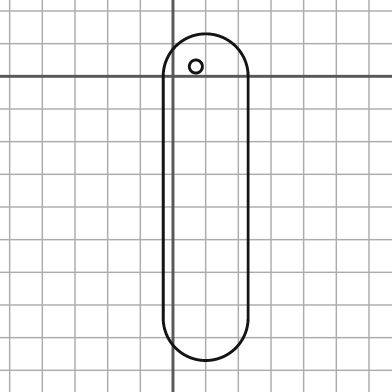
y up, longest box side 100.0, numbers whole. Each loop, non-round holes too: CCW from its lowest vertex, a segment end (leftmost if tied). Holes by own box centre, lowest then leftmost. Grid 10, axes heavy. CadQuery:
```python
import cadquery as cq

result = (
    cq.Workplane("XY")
    .moveTo(-3.0, -74.0)
    .threePointArc((10.0, -87.0), (23.0, -74.0))
    .lineTo(23.0, 0.0)
    .threePointArc((10.0, 13.0), (-3.0, 0.0))
    .close()
    .moveTo(7.0, 3.0)
    .circle(2.0)
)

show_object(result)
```